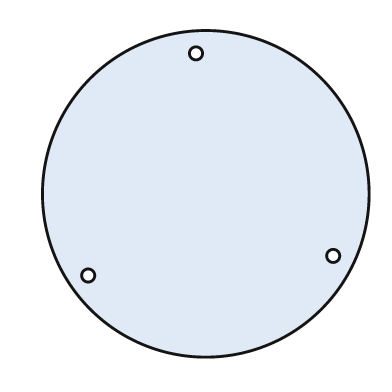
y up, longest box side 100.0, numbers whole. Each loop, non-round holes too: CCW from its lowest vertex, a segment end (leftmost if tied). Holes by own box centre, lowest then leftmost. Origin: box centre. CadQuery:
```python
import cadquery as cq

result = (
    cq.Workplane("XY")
    .moveTo(0.0, 0.0)
    .circle(50.0)
    .moveTo(-36.0, -25.0)
    .circle(2.0)
    .moveTo(39.0, -19.0)
    .circle(2.0)
    .moveTo(-3.0, 43.0)
    .circle(2.0)
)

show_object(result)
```